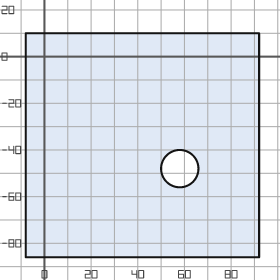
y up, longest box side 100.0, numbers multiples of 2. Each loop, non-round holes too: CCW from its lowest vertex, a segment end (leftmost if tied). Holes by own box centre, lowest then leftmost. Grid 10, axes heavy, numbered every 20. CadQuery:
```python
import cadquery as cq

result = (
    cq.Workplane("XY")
    .moveTo(-8.0, -86.0)
    .lineTo(92.0, -86.0)
    .lineTo(92.0, 10.0)
    .lineTo(-8.0, 10.0)
    .close()
    .moveTo(58.0, -48.0)
    .circle(8.0)
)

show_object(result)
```